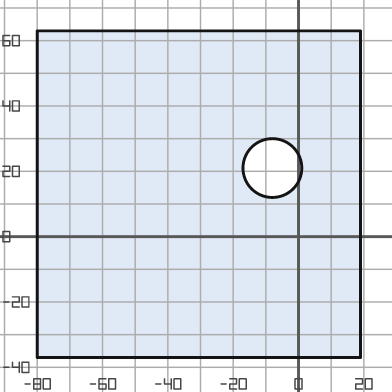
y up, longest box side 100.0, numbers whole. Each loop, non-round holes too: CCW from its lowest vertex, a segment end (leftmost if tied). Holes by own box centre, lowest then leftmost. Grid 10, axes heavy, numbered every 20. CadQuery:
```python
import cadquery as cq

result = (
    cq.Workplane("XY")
    .moveTo(-80.0, -37.0)
    .lineTo(19.0, -37.0)
    .lineTo(19.0, 63.0)
    .lineTo(-80.0, 63.0)
    .close()
    .moveTo(-8.0, 21.0)
    .circle(9.0)
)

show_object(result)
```